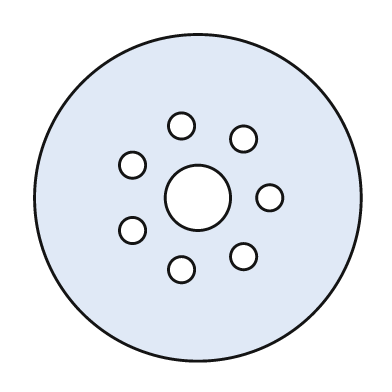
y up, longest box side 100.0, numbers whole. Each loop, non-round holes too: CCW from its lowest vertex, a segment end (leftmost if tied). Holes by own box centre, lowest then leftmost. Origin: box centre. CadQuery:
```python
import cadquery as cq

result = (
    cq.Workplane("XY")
    .moveTo(0.0, 0.0)
    .circle(50.0)
    .moveTo(-5.0, -22.0)
    .circle(4.0)
    .moveTo(14.0, -18.0)
    .circle(4.0)
    .moveTo(-20.0, -10.0)
    .circle(4.0)
    .moveTo(0.0, 0.0)
    .circle(10.0)
    .moveTo(22.0, 0.0)
    .circle(4.0)
    .moveTo(-20.0, 10.0)
    .circle(4.0)
    .moveTo(14.0, 18.0)
    .circle(4.0)
    .moveTo(-5.0, 22.0)
    .circle(4.0)
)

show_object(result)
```